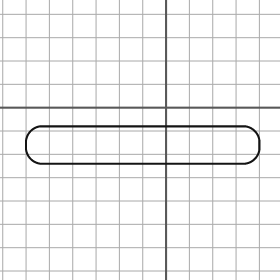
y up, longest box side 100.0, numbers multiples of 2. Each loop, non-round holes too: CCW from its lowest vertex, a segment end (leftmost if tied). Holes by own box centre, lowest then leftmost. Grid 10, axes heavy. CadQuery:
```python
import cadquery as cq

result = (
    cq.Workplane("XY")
    .moveTo(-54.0, -24.0)
    .lineTo(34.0, -24.0)
    .threePointArc((38.0, -22.0), (40.0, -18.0))
    .lineTo(40.0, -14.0)
    .threePointArc((38.0, -10.0), (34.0, -8.0))
    .lineTo(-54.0, -8.0)
    .threePointArc((-58.0, -10.0), (-60.0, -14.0))
    .lineTo(-60.0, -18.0)
    .threePointArc((-58.0, -22.0), (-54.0, -24.0))
    .close()
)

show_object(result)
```